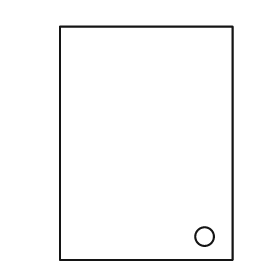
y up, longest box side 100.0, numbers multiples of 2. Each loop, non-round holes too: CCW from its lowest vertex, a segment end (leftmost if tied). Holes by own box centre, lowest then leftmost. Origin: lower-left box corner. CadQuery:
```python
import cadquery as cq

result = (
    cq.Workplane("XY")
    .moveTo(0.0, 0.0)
    .lineTo(74.0, 0.0)
    .lineTo(74.0, 100.0)
    .lineTo(0.0, 100.0)
    .close()
    .moveTo(62.0, 10.0)
    .circle(4.0)
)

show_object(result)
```